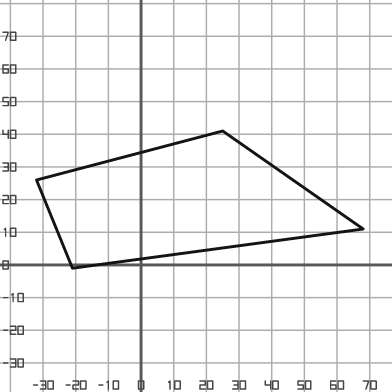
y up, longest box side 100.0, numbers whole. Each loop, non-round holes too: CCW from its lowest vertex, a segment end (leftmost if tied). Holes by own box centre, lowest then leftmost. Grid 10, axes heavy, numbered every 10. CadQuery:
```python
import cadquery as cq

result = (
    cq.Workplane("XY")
    .moveTo(-21.0, -1.0)
    .lineTo(68.0, 11.0)
    .lineTo(25.0, 41.0)
    .lineTo(-32.0, 26.0)
    .close()
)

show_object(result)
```